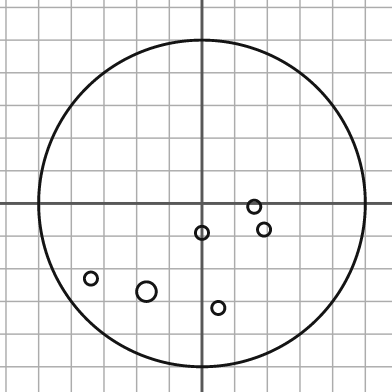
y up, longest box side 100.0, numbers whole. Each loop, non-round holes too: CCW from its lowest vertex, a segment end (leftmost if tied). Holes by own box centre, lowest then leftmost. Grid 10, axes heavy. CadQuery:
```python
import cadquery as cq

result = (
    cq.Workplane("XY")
    .moveTo(0.0, 0.0)
    .circle(50.0)
    .moveTo(5.0, -32.0)
    .circle(2.0)
    .moveTo(-17.0, -27.0)
    .circle(3.0)
    .moveTo(-34.0, -23.0)
    .circle(2.0)
    .moveTo(0.0, -9.0)
    .circle(2.0)
    .moveTo(19.0, -8.0)
    .circle(2.0)
    .moveTo(16.0, -1.0)
    .circle(2.0)
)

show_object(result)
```